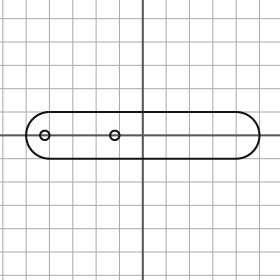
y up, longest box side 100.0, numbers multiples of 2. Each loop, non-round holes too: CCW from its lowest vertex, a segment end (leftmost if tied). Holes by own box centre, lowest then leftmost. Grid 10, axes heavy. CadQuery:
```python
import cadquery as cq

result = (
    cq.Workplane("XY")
    .moveTo(-40.0, -10.0)
    .lineTo(40.0, -10.0)
    .threePointArc((50.0, 0.0), (40.0, 10.0))
    .lineTo(-40.0, 10.0)
    .threePointArc((-50.0, 0.0), (-40.0, -10.0))
    .close()
    .moveTo(-42.0, 0.0)
    .circle(2.0)
    .moveTo(-12.0, 0.0)
    .circle(2.0)
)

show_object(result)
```